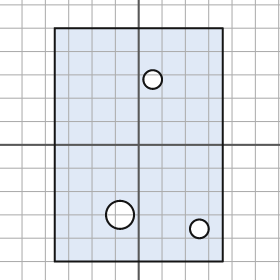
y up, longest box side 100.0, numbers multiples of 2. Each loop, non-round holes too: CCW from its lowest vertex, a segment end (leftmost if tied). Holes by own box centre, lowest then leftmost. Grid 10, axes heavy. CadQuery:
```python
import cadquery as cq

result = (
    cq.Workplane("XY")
    .moveTo(-36.0, -50.0)
    .lineTo(36.0, -50.0)
    .lineTo(36.0, 50.0)
    .lineTo(-36.0, 50.0)
    .close()
    .moveTo(26.0, -36.0)
    .circle(4.0)
    .moveTo(-8.0, -30.0)
    .circle(6.0)
    .moveTo(6.0, 28.0)
    .circle(4.0)
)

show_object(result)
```